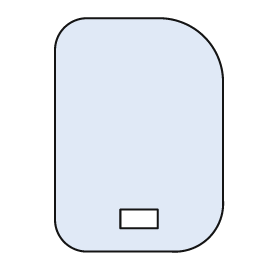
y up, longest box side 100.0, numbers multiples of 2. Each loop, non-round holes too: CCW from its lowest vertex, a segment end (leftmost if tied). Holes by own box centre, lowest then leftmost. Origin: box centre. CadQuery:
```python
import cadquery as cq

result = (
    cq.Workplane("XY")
    .moveTo(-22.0, -50.0)
    .lineTo(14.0, -50.0)
    .threePointArc((30.0, -44.0), (36.0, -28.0))
    .lineTo(36.0, 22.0)
    .threePointArc((28.0, 42.0), (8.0, 50.0))
    .lineTo(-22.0, 50.0)
    .threePointArc((-32.0, 46.0), (-36.0, 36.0))
    .lineTo(-36.0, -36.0)
    .threePointArc((-32.0, -46.0), (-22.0, -50.0))
    .close()
    .moveTo(-8.0, -40.0)
    .lineTo(8.0, -40.0)
    .lineTo(8.0, -32.0)
    .lineTo(-8.0, -32.0)
    .close()
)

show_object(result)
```